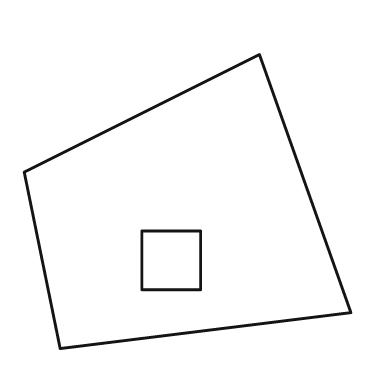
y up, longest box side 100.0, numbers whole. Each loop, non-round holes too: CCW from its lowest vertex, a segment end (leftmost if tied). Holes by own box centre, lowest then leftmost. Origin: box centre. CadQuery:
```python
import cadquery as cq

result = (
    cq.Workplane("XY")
    .moveTo(-39.0, -45.0)
    .lineTo(50.0, -34.0)
    .lineTo(22.0, 45.0)
    .lineTo(-50.0, 9.0)
    .close()
    .moveTo(-14.0, -27.0)
    .lineTo(4.0, -27.0)
    .lineTo(4.0, -9.0)
    .lineTo(-14.0, -9.0)
    .close()
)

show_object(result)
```